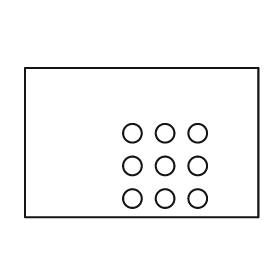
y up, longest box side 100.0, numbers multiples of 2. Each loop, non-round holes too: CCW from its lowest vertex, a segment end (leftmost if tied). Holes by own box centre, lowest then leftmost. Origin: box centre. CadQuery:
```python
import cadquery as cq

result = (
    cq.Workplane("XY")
    .moveTo(-50.0, -32.0)
    .lineTo(50.0, -32.0)
    .lineTo(50.0, 32.0)
    .lineTo(-50.0, 32.0)
    .close()
    .moveTo(-4.0, -24.0)
    .circle(4.0)
    .moveTo(10.0, -24.0)
    .circle(4.0)
    .moveTo(24.0, -24.0)
    .circle(4.0)
    .moveTo(-4.0, -10.0)
    .circle(4.0)
    .moveTo(10.0, -10.0)
    .circle(4.0)
    .moveTo(24.0, -10.0)
    .circle(4.0)
    .moveTo(-4.0, 4.0)
    .circle(4.0)
    .moveTo(10.0, 4.0)
    .circle(4.0)
    .moveTo(24.0, 4.0)
    .circle(4.0)
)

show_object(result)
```